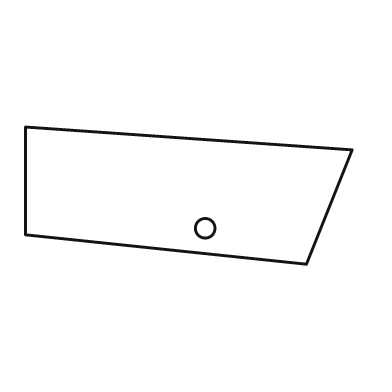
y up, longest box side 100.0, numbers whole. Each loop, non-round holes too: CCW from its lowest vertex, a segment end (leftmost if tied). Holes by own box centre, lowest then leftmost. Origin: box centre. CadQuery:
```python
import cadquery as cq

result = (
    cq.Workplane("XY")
    .moveTo(36.0, -21.0)
    .lineTo(50.0, 14.0)
    .lineTo(-50.0, 21.0)
    .lineTo(-50.0, -12.0)
    .close()
    .moveTo(5.0, -10.0)
    .circle(3.0)
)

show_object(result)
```